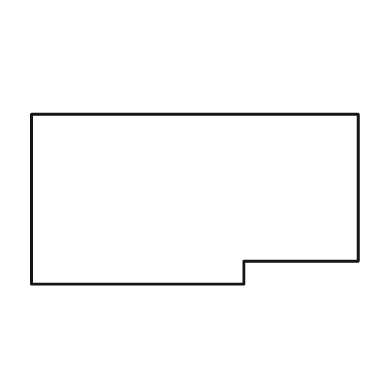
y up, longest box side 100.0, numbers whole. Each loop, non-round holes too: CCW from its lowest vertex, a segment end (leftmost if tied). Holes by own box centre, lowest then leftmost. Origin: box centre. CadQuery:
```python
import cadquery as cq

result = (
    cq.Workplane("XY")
    .moveTo(-50.0, -26.0)
    .lineTo(15.0, -26.0)
    .lineTo(15.0, -19.0)
    .lineTo(50.0, -19.0)
    .lineTo(50.0, 26.0)
    .lineTo(-50.0, 26.0)
    .close()
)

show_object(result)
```